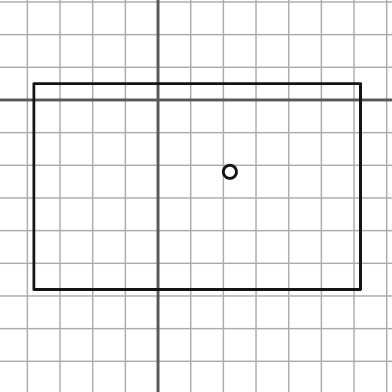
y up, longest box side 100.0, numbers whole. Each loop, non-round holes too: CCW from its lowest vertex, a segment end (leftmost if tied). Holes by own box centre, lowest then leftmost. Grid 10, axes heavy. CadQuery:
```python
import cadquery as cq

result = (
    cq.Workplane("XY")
    .moveTo(-38.0, -58.0)
    .lineTo(62.0, -58.0)
    .lineTo(62.0, 5.0)
    .lineTo(-38.0, 5.0)
    .close()
    .moveTo(22.0, -22.0)
    .circle(2.0)
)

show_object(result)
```